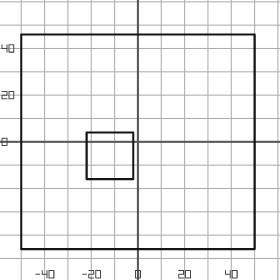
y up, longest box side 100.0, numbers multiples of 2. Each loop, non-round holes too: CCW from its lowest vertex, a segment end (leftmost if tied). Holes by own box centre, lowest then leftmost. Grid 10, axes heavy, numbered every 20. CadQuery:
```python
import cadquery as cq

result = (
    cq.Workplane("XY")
    .moveTo(-50.0, -46.0)
    .lineTo(50.0, -46.0)
    .lineTo(50.0, 46.0)
    .lineTo(-50.0, 46.0)
    .close()
    .moveTo(-22.0, -16.0)
    .lineTo(-2.0, -16.0)
    .lineTo(-2.0, 4.0)
    .lineTo(-22.0, 4.0)
    .close()
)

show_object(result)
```